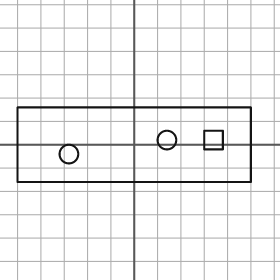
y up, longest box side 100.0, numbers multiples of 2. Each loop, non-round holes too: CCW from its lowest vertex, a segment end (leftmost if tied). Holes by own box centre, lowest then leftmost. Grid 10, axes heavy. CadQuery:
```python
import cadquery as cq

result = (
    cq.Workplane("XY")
    .moveTo(-50.0, -16.0)
    .lineTo(50.0, -16.0)
    .lineTo(50.0, 16.0)
    .lineTo(-50.0, 16.0)
    .close()
    .moveTo(-28.0, -4.0)
    .circle(4.0)
    .moveTo(14.0, 2.0)
    .circle(4.0)
    .moveTo(30.0, -2.0)
    .lineTo(38.0, -2.0)
    .lineTo(38.0, 6.0)
    .lineTo(30.0, 6.0)
    .close()
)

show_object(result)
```